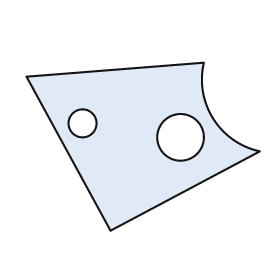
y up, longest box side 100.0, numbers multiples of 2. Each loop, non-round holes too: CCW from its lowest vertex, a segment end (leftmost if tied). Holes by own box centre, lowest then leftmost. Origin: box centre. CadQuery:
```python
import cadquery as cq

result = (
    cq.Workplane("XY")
    .moveTo(-14.0, -36.0)
    .lineTo(50.0, -2.0)
    .threePointArc((30.0, 12.0), (26.0, 36.0))
    .lineTo(-50.0, 30.0)
    .close()
    .moveTo(16.0, 4.0)
    .circle(10.0)
    .moveTo(-26.0, 10.0)
    .circle(6.0)
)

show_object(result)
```